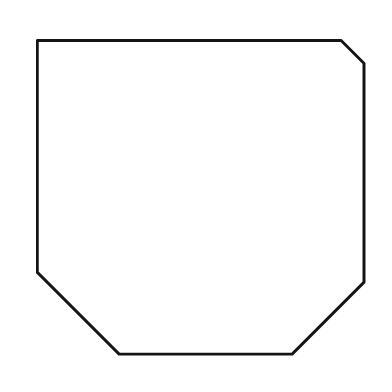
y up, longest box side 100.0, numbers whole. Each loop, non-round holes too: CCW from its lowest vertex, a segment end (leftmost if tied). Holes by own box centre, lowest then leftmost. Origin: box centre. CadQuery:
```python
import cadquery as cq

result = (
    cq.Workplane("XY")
    .moveTo(-25.0, -48.0)
    .lineTo(28.0, -48.0)
    .lineTo(50.0, -26.0)
    .lineTo(50.0, 41.0)
    .lineTo(43.0, 48.0)
    .lineTo(-50.0, 48.0)
    .lineTo(-50.0, -23.0)
    .close()
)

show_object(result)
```